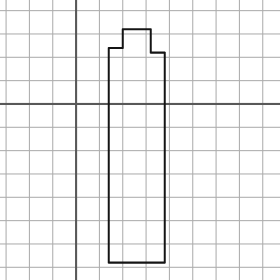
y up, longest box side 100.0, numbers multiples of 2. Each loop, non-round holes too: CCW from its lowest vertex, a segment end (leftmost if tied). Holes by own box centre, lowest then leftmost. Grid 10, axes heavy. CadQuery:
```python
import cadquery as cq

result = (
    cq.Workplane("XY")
    .moveTo(14.0, -68.0)
    .lineTo(38.0, -68.0)
    .lineTo(38.0, 22.0)
    .lineTo(32.0, 22.0)
    .lineTo(32.0, 32.0)
    .lineTo(20.0, 32.0)
    .lineTo(20.0, 24.0)
    .lineTo(14.0, 24.0)
    .close()
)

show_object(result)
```